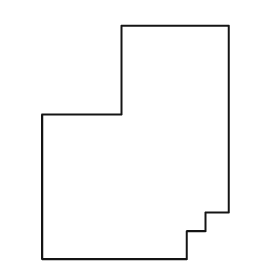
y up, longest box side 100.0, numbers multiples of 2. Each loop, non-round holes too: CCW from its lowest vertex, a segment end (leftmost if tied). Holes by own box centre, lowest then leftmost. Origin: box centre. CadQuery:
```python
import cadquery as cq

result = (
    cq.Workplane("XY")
    .moveTo(-40.0, -50.0)
    .lineTo(22.0, -50.0)
    .lineTo(22.0, -38.0)
    .lineTo(30.0, -38.0)
    .lineTo(30.0, -30.0)
    .lineTo(40.0, -30.0)
    .lineTo(40.0, 50.0)
    .lineTo(-6.0, 50.0)
    .lineTo(-6.0, 12.0)
    .lineTo(-40.0, 12.0)
    .close()
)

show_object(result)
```